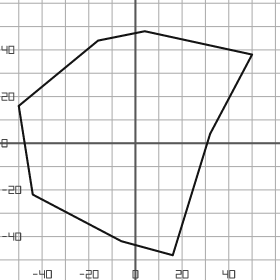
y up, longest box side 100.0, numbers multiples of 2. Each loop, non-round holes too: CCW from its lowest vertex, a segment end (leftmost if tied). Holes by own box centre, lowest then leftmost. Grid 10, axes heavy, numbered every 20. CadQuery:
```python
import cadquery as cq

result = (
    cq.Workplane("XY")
    .moveTo(16.0, -48.0)
    .lineTo(32.0, 4.0)
    .lineTo(50.0, 38.0)
    .lineTo(4.0, 48.0)
    .lineTo(-16.0, 44.0)
    .lineTo(-50.0, 16.0)
    .lineTo(-44.0, -22.0)
    .lineTo(-6.0, -42.0)
    .close()
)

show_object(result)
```